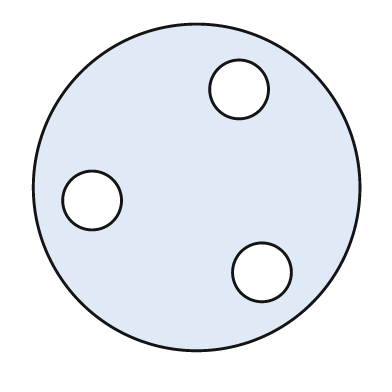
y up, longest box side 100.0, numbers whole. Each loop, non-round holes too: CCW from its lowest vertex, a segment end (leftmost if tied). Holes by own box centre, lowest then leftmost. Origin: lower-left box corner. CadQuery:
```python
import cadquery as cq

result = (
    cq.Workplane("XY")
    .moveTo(50.0, 50.0)
    .circle(50.0)
    .moveTo(70.0, 24.0)
    .circle(9.0)
    .moveTo(18.0, 46.0)
    .circle(9.0)
    .moveTo(63.0, 80.0)
    .circle(9.0)
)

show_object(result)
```